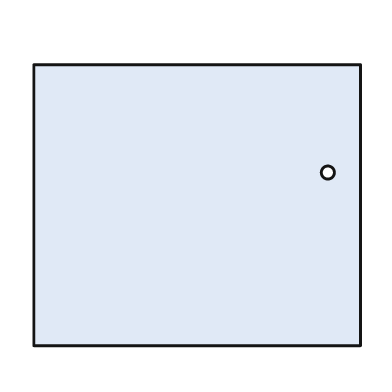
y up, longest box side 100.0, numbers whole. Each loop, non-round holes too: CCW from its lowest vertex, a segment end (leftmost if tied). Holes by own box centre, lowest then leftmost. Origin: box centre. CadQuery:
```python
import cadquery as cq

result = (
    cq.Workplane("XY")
    .moveTo(-50.0, -43.0)
    .lineTo(50.0, -43.0)
    .lineTo(50.0, 43.0)
    .lineTo(-50.0, 43.0)
    .close()
    .moveTo(40.0, 10.0)
    .circle(2.0)
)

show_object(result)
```